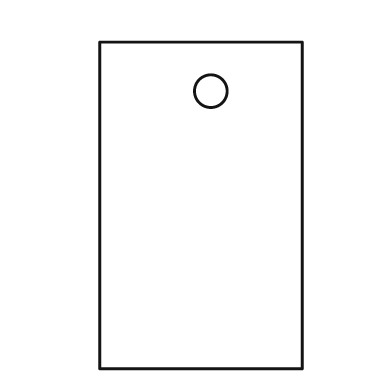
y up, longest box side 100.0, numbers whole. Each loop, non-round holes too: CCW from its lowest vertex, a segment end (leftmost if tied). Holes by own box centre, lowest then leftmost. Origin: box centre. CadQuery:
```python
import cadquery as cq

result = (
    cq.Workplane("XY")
    .moveTo(-31.0, -50.0)
    .lineTo(31.0, -50.0)
    .lineTo(31.0, 50.0)
    .lineTo(-31.0, 50.0)
    .close()
    .moveTo(3.0, 35.0)
    .circle(5.0)
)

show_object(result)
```